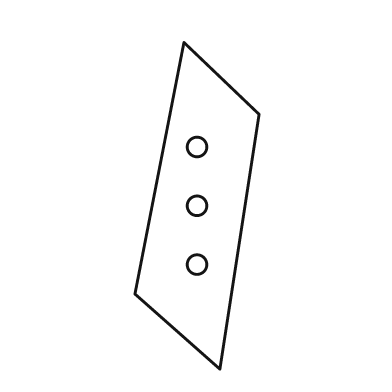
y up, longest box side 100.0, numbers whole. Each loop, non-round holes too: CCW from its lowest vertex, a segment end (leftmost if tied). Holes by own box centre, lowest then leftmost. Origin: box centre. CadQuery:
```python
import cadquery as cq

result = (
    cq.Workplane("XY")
    .moveTo(7.0, -50.0)
    .lineTo(19.0, 28.0)
    .lineTo(-4.0, 50.0)
    .lineTo(-19.0, -27.0)
    .close()
    .moveTo(0.0, -18.0)
    .circle(3.0)
    .moveTo(0.0, 0.0)
    .circle(3.0)
    .moveTo(0.0, 18.0)
    .circle(3.0)
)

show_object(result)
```